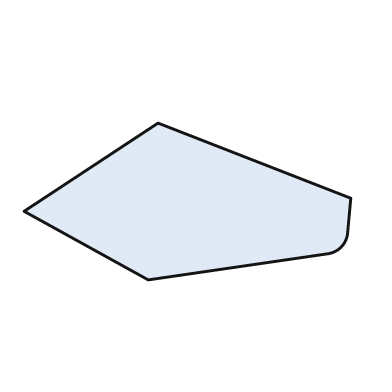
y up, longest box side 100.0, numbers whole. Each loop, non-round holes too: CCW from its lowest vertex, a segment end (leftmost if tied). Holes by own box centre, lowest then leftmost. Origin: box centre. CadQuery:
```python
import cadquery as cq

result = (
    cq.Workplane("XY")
    .moveTo(-12.0, -24.0)
    .lineTo(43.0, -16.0)
    .threePointArc((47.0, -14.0), (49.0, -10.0))
    .lineTo(50.0, 1.0)
    .lineTo(-9.0, 24.0)
    .lineTo(-50.0, -3.0)
    .close()
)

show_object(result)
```